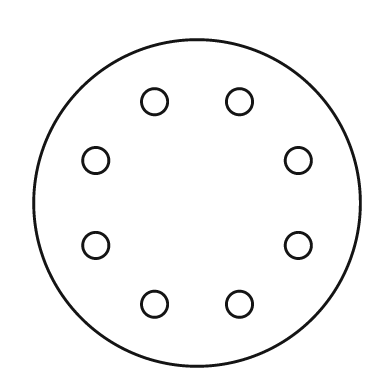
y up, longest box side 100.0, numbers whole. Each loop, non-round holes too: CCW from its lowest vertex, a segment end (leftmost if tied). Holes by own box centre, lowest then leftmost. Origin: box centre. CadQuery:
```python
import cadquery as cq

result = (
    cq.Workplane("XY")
    .moveTo(0.0, 0.0)
    .circle(50.0)
    .moveTo(-13.0, -31.0)
    .circle(4.0)
    .moveTo(13.0, -31.0)
    .circle(4.0)
    .moveTo(-31.0, -13.0)
    .circle(4.0)
    .moveTo(31.0, -13.0)
    .circle(4.0)
    .moveTo(-31.0, 13.0)
    .circle(4.0)
    .moveTo(31.0, 13.0)
    .circle(4.0)
    .moveTo(-13.0, 31.0)
    .circle(4.0)
    .moveTo(13.0, 31.0)
    .circle(4.0)
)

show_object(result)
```